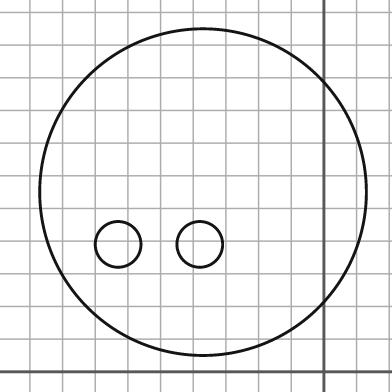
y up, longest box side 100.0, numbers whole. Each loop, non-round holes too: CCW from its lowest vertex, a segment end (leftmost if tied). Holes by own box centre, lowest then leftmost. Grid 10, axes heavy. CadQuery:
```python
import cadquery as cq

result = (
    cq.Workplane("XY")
    .moveTo(-37.0, 55.0)
    .circle(50.0)
    .moveTo(-63.0, 39.0)
    .circle(7.0)
    .moveTo(-38.0, 39.0)
    .circle(7.0)
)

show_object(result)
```